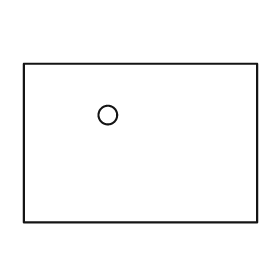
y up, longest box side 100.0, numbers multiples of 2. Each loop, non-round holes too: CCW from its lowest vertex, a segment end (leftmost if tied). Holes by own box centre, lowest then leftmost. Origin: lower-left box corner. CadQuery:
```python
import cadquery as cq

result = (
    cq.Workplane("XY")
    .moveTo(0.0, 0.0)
    .lineTo(100.0, 0.0)
    .lineTo(100.0, 68.0)
    .lineTo(0.0, 68.0)
    .close()
    .moveTo(36.0, 46.0)
    .circle(4.0)
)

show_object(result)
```